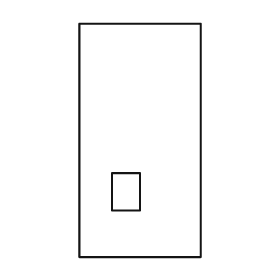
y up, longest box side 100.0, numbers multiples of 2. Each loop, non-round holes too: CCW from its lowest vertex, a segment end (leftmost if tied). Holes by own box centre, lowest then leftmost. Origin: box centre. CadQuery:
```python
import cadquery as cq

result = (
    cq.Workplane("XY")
    .moveTo(-26.0, -50.0)
    .lineTo(26.0, -50.0)
    .lineTo(26.0, 50.0)
    .lineTo(-26.0, 50.0)
    .close()
    .moveTo(-12.0, -30.0)
    .lineTo(0.0, -30.0)
    .lineTo(0.0, -14.0)
    .lineTo(-12.0, -14.0)
    .close()
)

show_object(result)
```